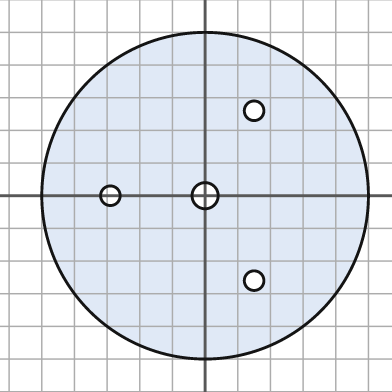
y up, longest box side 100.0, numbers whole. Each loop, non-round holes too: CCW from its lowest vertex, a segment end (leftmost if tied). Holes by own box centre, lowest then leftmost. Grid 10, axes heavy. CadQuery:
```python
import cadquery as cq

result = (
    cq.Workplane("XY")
    .moveTo(0.0, 0.0)
    .circle(50.0)
    .moveTo(15.0, -26.0)
    .circle(3.0)
    .moveTo(-29.0, 0.0)
    .circle(3.0)
    .moveTo(0.0, 0.0)
    .circle(4.0)
    .moveTo(15.0, 26.0)
    .circle(3.0)
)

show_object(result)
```